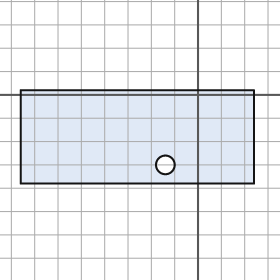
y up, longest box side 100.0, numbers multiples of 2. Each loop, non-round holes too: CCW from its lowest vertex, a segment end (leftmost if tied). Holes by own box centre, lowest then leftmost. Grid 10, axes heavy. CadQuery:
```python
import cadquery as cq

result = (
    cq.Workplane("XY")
    .moveTo(-76.0, -38.0)
    .lineTo(24.0, -38.0)
    .lineTo(24.0, 2.0)
    .lineTo(-76.0, 2.0)
    .close()
    .moveTo(-14.0, -30.0)
    .circle(4.0)
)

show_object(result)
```